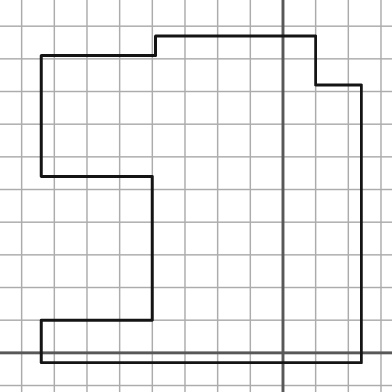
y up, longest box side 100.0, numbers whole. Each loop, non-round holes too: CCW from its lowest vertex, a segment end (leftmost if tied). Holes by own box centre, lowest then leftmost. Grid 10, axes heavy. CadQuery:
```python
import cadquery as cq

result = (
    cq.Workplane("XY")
    .moveTo(-74.0, -3.0)
    .lineTo(24.0, -3.0)
    .lineTo(24.0, 82.0)
    .lineTo(10.0, 82.0)
    .lineTo(10.0, 97.0)
    .lineTo(-39.0, 97.0)
    .lineTo(-39.0, 91.0)
    .lineTo(-74.0, 91.0)
    .lineTo(-74.0, 54.0)
    .lineTo(-40.0, 54.0)
    .lineTo(-40.0, 10.0)
    .lineTo(-74.0, 10.0)
    .close()
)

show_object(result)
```